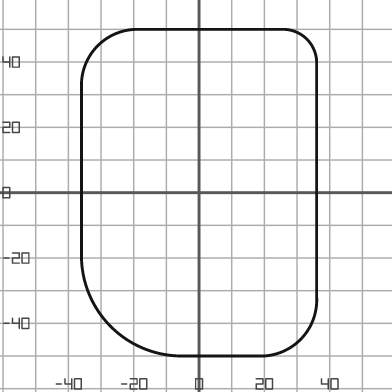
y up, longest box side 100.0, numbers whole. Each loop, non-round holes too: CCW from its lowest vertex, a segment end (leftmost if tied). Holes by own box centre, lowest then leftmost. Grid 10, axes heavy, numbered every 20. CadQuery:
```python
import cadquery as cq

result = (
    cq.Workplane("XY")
    .moveTo(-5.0, -50.0)
    .lineTo(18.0, -50.0)
    .threePointArc((31.0, -45.0), (36.0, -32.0))
    .lineTo(36.0, 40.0)
    .threePointArc((33.0, 47.0), (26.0, 50.0))
    .lineTo(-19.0, 50.0)
    .threePointArc((-31.0, 45.0), (-36.0, 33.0))
    .lineTo(-36.0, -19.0)
    .threePointArc((-27.0, -41.0), (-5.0, -50.0))
    .close()
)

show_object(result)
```